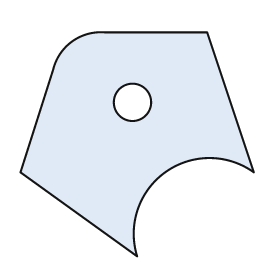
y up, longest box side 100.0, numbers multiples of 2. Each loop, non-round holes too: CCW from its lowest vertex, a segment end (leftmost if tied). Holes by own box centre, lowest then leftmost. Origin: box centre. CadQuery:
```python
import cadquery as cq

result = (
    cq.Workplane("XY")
    .moveTo(0.0, -48.0)
    .threePointArc((12.0, -12.0), (50.0, -12.0))
    .lineTo(30.0, 48.0)
    .lineTo(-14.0, 48.0)
    .threePointArc((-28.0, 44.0), (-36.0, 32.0))
    .lineTo(-50.0, -12.0)
    .close()
    .moveTo(-2.0, 18.0)
    .circle(8.0)
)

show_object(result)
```